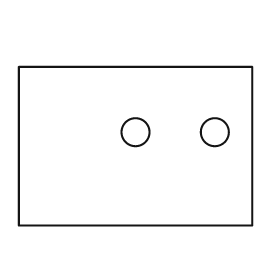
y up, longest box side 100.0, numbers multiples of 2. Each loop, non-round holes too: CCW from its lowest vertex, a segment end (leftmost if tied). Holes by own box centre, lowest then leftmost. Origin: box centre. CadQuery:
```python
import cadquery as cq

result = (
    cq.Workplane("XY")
    .moveTo(-50.0, -34.0)
    .lineTo(50.0, -34.0)
    .lineTo(50.0, 34.0)
    .lineTo(-50.0, 34.0)
    .close()
    .moveTo(0.0, 6.0)
    .circle(6.0)
    .moveTo(34.0, 6.0)
    .circle(6.0)
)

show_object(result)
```